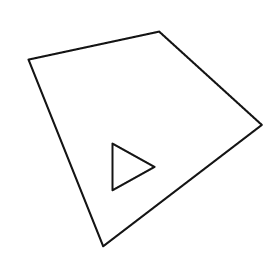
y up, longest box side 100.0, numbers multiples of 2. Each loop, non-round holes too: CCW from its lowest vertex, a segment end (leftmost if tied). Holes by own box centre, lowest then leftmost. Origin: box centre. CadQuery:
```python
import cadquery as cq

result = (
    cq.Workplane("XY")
    .moveTo(-18.0, -46.0)
    .lineTo(50.0, 6.0)
    .lineTo(6.0, 46.0)
    .lineTo(-50.0, 34.0)
    .close()
    .moveTo(-14.0, -22.0)
    .lineTo(4.0, -12.0)
    .lineTo(-14.0, -2.0)
    .close()
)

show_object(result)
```